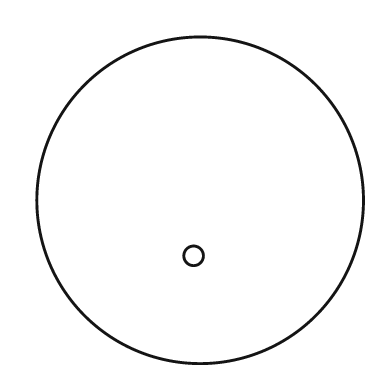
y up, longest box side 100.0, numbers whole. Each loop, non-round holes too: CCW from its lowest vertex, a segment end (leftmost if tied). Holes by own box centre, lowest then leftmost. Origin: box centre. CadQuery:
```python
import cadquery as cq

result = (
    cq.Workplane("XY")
    .moveTo(0.0, 0.0)
    .circle(50.0)
    .moveTo(-2.0, -17.0)
    .circle(3.0)
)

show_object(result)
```